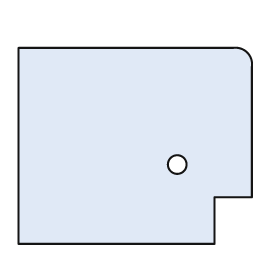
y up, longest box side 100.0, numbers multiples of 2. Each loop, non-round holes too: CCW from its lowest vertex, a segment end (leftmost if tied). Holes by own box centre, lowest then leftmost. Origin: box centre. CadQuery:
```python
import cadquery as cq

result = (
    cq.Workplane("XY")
    .moveTo(-50.0, -42.0)
    .lineTo(34.0, -42.0)
    .lineTo(34.0, -22.0)
    .lineTo(50.0, -22.0)
    .lineTo(50.0, 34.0)
    .threePointArc((48.0, 40.0), (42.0, 42.0))
    .lineTo(-50.0, 42.0)
    .close()
    .moveTo(18.0, -8.0)
    .circle(4.0)
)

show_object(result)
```